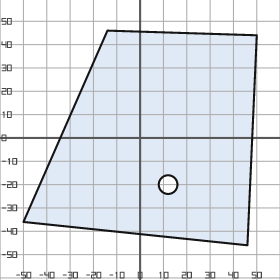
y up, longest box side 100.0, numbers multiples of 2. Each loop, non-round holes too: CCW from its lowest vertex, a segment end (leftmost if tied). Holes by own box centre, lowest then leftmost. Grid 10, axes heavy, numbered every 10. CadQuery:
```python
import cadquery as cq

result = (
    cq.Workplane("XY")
    .moveTo(46.0, -46.0)
    .lineTo(50.0, 44.0)
    .lineTo(-14.0, 46.0)
    .lineTo(-50.0, -36.0)
    .close()
    .moveTo(12.0, -20.0)
    .circle(4.0)
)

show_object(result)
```